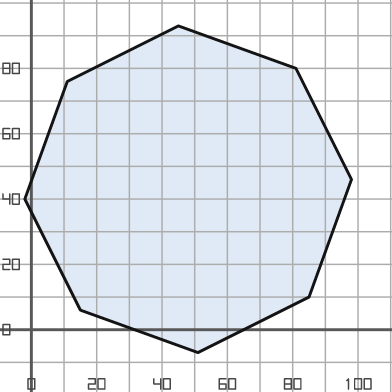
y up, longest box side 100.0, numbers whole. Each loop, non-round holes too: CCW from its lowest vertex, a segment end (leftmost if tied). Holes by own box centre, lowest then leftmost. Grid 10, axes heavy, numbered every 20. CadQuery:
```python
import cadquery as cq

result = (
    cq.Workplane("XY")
    .moveTo(51.0, -7.0)
    .lineTo(85.0, 10.0)
    .lineTo(98.0, 46.0)
    .lineTo(81.0, 80.0)
    .lineTo(45.0, 93.0)
    .lineTo(11.0, 76.0)
    .lineTo(-2.0, 40.0)
    .lineTo(15.0, 6.0)
    .close()
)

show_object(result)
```